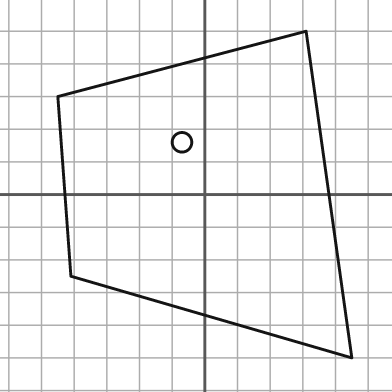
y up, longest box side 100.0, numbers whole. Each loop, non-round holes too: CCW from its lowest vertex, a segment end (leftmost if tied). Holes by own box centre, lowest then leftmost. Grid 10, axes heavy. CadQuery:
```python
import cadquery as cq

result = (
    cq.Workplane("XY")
    .moveTo(45.0, -50.0)
    .lineTo(31.0, 50.0)
    .lineTo(-45.0, 30.0)
    .lineTo(-41.0, -25.0)
    .close()
    .moveTo(-7.0, 16.0)
    .circle(3.0)
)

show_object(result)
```